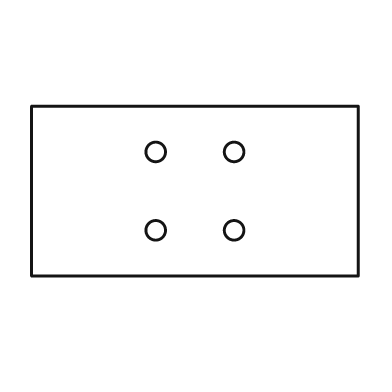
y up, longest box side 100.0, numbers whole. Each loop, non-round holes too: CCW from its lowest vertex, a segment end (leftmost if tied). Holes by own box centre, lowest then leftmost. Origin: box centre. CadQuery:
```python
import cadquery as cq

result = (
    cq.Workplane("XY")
    .moveTo(-50.0, -26.0)
    .lineTo(50.0, -26.0)
    .lineTo(50.0, 26.0)
    .lineTo(-50.0, 26.0)
    .close()
    .moveTo(-12.0, -12.0)
    .circle(3.0)
    .moveTo(12.0, -12.0)
    .circle(3.0)
    .moveTo(-12.0, 12.0)
    .circle(3.0)
    .moveTo(12.0, 12.0)
    .circle(3.0)
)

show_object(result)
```